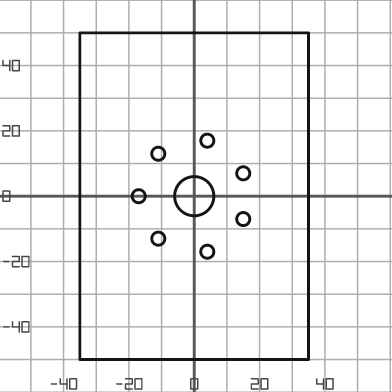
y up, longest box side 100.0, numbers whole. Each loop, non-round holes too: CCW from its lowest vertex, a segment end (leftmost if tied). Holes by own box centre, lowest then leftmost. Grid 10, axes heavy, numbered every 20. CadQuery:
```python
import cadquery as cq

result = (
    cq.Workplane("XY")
    .moveTo(-35.0, -50.0)
    .lineTo(35.0, -50.0)
    .lineTo(35.0, 50.0)
    .lineTo(-35.0, 50.0)
    .close()
    .moveTo(4.0, -17.0)
    .circle(2.0)
    .moveTo(-11.0, -13.0)
    .circle(2.0)
    .moveTo(15.0, -7.0)
    .circle(2.0)
    .moveTo(-17.0, 0.0)
    .circle(2.0)
    .moveTo(0.0, 0.0)
    .circle(6.0)
    .moveTo(15.0, 7.0)
    .circle(2.0)
    .moveTo(-11.0, 13.0)
    .circle(2.0)
    .moveTo(4.0, 17.0)
    .circle(2.0)
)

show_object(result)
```